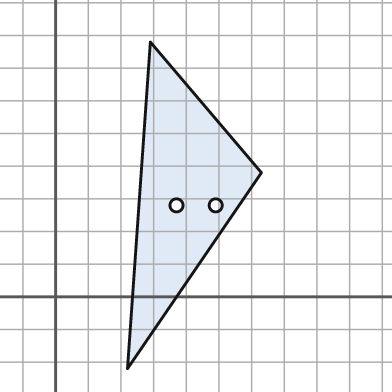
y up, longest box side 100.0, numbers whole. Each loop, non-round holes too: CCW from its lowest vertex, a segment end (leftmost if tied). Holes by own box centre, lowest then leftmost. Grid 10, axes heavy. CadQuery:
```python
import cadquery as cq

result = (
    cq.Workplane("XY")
    .moveTo(22.0, -22.0)
    .lineTo(63.0, 38.0)
    .lineTo(29.0, 78.0)
    .close()
    .moveTo(37.0, 28.0)
    .circle(2.0)
    .moveTo(49.0, 28.0)
    .circle(2.0)
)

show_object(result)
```